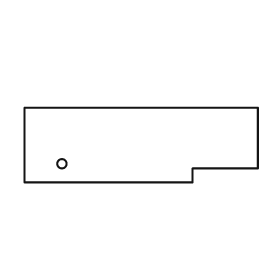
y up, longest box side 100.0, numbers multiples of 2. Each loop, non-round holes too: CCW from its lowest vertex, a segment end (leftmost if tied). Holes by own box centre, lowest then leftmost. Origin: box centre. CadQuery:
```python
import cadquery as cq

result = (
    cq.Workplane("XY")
    .moveTo(-50.0, -16.0)
    .lineTo(22.0, -16.0)
    .lineTo(22.0, -10.0)
    .lineTo(50.0, -10.0)
    .lineTo(50.0, 16.0)
    .lineTo(-50.0, 16.0)
    .close()
    .moveTo(-34.0, -8.0)
    .circle(2.0)
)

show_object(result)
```